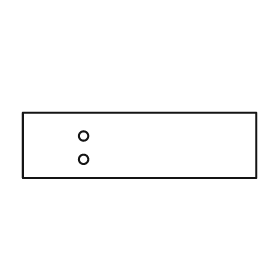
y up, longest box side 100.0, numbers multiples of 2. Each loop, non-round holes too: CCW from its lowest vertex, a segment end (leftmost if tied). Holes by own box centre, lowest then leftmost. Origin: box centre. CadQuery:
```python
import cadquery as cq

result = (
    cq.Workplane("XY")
    .moveTo(-50.0, -14.0)
    .lineTo(50.0, -14.0)
    .lineTo(50.0, 14.0)
    .lineTo(-50.0, 14.0)
    .close()
    .moveTo(-24.0, -6.0)
    .circle(2.0)
    .moveTo(-24.0, 4.0)
    .circle(2.0)
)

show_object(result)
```